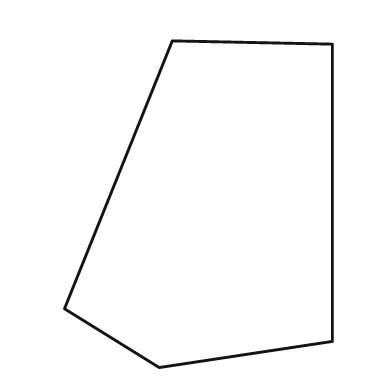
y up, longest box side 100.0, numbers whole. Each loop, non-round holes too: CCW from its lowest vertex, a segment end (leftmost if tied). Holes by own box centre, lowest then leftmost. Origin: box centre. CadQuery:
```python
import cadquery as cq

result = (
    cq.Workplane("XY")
    .moveTo(-12.0, -50.0)
    .lineTo(41.0, -42.0)
    .lineTo(41.0, 49.0)
    .lineTo(-8.0, 50.0)
    .lineTo(-41.0, -32.0)
    .close()
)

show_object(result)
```